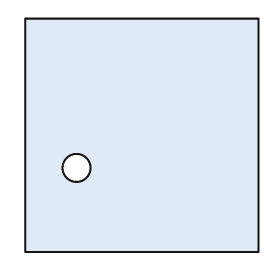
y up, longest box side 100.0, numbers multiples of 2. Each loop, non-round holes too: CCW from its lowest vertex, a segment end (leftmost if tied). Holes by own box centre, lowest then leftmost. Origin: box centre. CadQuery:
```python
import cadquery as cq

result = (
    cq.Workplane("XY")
    .moveTo(-50.0, -50.0)
    .lineTo(50.0, -50.0)
    .lineTo(50.0, 50.0)
    .lineTo(-50.0, 50.0)
    .close()
    .moveTo(-28.0, -14.0)
    .circle(6.0)
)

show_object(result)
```